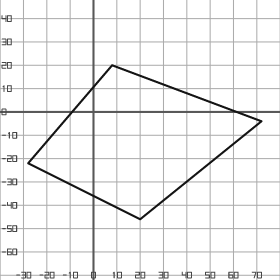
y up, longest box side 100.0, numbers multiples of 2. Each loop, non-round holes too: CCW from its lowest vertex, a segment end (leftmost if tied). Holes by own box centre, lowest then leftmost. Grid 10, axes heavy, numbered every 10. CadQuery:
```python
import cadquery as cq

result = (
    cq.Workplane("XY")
    .moveTo(20.0, -46.0)
    .lineTo(72.0, -4.0)
    .lineTo(8.0, 20.0)
    .lineTo(-28.0, -22.0)
    .close()
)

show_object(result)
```